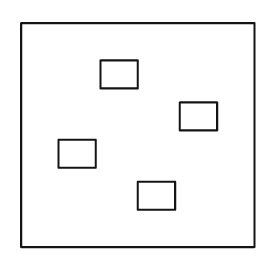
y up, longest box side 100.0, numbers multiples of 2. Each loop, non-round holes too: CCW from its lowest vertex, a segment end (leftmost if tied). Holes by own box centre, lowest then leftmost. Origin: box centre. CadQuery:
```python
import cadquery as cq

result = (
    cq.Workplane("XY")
    .moveTo(-50.0, -48.0)
    .lineTo(50.0, -48.0)
    .lineTo(50.0, 48.0)
    .lineTo(-50.0, 48.0)
    .close()
    .moveTo(0.0, -32.0)
    .lineTo(16.0, -32.0)
    .lineTo(16.0, -20.0)
    .lineTo(0.0, -20.0)
    .close()
    .moveTo(-34.0, -14.0)
    .lineTo(-18.0, -14.0)
    .lineTo(-18.0, -2.0)
    .lineTo(-34.0, -2.0)
    .close()
    .moveTo(18.0, 2.0)
    .lineTo(34.0, 2.0)
    .lineTo(34.0, 14.0)
    .lineTo(18.0, 14.0)
    .close()
    .moveTo(-16.0, 20.0)
    .lineTo(0.0, 20.0)
    .lineTo(0.0, 32.0)
    .lineTo(-16.0, 32.0)
    .close()
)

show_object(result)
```